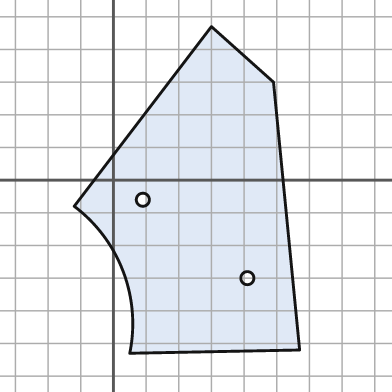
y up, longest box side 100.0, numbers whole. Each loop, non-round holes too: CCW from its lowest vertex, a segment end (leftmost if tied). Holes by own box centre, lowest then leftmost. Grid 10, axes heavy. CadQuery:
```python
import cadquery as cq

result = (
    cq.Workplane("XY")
    .moveTo(5.0, -53.0)
    .lineTo(57.0, -52.0)
    .lineTo(49.0, 30.0)
    .lineTo(30.0, 47.0)
    .lineTo(-12.0, -8.0)
    .threePointArc((3.0, -28.0), (5.0, -53.0))
    .close()
    .moveTo(41.0, -30.0)
    .circle(2.0)
    .moveTo(9.0, -6.0)
    .circle(2.0)
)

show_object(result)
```